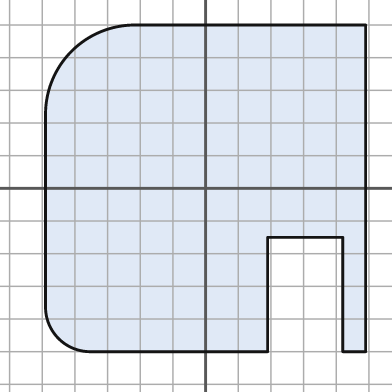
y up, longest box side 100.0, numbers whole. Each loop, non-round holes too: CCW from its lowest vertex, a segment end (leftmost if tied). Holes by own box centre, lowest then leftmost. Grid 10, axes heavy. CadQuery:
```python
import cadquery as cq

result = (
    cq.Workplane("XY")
    .moveTo(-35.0, -50.0)
    .lineTo(19.0, -50.0)
    .lineTo(19.0, -15.0)
    .lineTo(42.0, -15.0)
    .lineTo(42.0, -50.0)
    .lineTo(49.0, -50.0)
    .lineTo(49.0, 50.0)
    .lineTo(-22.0, 50.0)
    .threePointArc((-41.0, 42.0), (-49.0, 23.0))
    .lineTo(-49.0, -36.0)
    .threePointArc((-45.0, -46.0), (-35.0, -50.0))
    .close()
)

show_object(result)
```